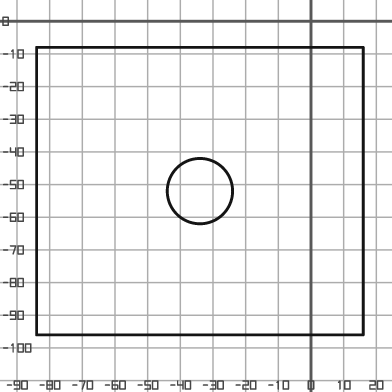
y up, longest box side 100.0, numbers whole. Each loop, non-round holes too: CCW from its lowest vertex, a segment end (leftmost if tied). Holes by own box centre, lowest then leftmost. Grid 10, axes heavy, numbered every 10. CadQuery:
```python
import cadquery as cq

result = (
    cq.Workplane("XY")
    .moveTo(-84.0, -96.0)
    .lineTo(16.0, -96.0)
    .lineTo(16.0, -8.0)
    .lineTo(-84.0, -8.0)
    .close()
    .moveTo(-34.0, -52.0)
    .circle(10.0)
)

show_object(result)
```